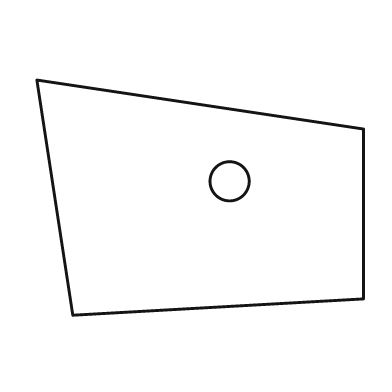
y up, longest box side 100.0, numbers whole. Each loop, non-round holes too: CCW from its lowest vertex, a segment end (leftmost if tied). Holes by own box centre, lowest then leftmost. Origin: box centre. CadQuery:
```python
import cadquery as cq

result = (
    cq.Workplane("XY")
    .moveTo(-39.0, -36.0)
    .lineTo(50.0, -31.0)
    .lineTo(50.0, 21.0)
    .lineTo(-50.0, 36.0)
    .close()
    .moveTo(9.0, 5.0)
    .circle(6.0)
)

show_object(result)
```